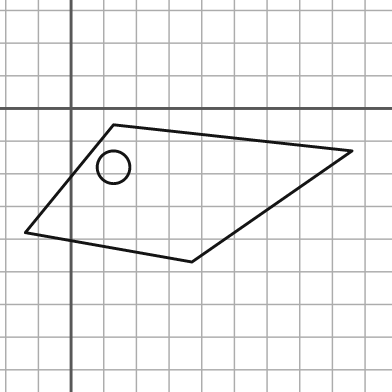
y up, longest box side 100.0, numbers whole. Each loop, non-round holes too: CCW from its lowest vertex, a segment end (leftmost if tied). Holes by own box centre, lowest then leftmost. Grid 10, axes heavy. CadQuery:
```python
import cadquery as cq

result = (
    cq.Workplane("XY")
    .moveTo(37.0, -47.0)
    .lineTo(86.0, -13.0)
    .lineTo(13.0, -5.0)
    .lineTo(-14.0, -38.0)
    .close()
    .moveTo(13.0, -18.0)
    .circle(5.0)
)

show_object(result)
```